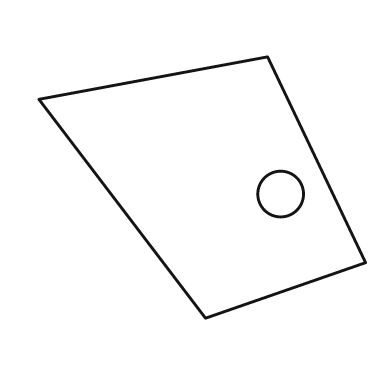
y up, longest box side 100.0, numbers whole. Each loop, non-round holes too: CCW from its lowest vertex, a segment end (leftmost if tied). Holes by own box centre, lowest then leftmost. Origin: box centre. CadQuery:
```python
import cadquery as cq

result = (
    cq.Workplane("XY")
    .moveTo(1.0, -40.0)
    .lineTo(50.0, -23.0)
    .lineTo(20.0, 40.0)
    .lineTo(-50.0, 27.0)
    .close()
    .moveTo(24.0, -2.0)
    .circle(7.0)
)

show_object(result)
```